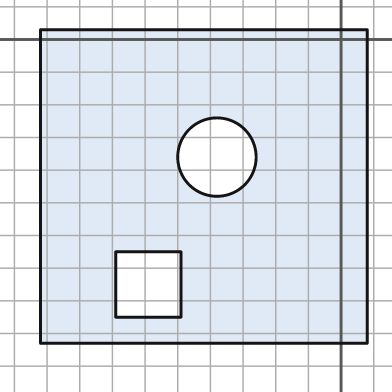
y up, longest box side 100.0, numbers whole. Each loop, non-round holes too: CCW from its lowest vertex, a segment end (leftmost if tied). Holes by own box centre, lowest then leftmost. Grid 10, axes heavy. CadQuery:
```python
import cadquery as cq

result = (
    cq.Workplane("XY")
    .moveTo(-92.0, -93.0)
    .lineTo(8.0, -93.0)
    .lineTo(8.0, 3.0)
    .lineTo(-92.0, 3.0)
    .close()
    .moveTo(-69.0, -85.0)
    .lineTo(-49.0, -85.0)
    .lineTo(-49.0, -65.0)
    .lineTo(-69.0, -65.0)
    .close()
    .moveTo(-38.0, -36.0)
    .circle(12.0)
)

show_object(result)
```